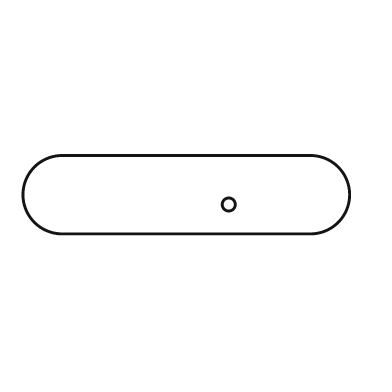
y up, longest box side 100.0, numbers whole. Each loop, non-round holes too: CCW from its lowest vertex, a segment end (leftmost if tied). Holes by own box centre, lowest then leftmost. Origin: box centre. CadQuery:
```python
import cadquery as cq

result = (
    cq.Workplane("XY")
    .moveTo(-38.0, -12.0)
    .lineTo(38.0, -12.0)
    .threePointArc((50.0, 0.0), (38.0, 12.0))
    .lineTo(-38.0, 12.0)
    .threePointArc((-50.0, 0.0), (-38.0, -12.0))
    .close()
    .moveTo(13.0, -3.0)
    .circle(2.0)
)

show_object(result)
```